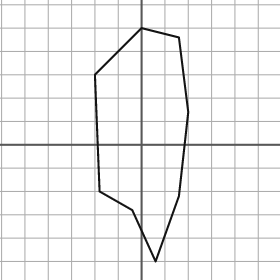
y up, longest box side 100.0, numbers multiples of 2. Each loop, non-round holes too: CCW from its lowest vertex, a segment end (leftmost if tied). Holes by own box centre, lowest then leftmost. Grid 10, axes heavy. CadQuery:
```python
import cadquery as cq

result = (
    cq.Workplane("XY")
    .moveTo(6.0, -50.0)
    .lineTo(16.0, -22.0)
    .lineTo(20.0, 14.0)
    .lineTo(16.0, 46.0)
    .lineTo(0.0, 50.0)
    .lineTo(-20.0, 30.0)
    .lineTo(-18.0, -20.0)
    .lineTo(-4.0, -28.0)
    .close()
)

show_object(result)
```